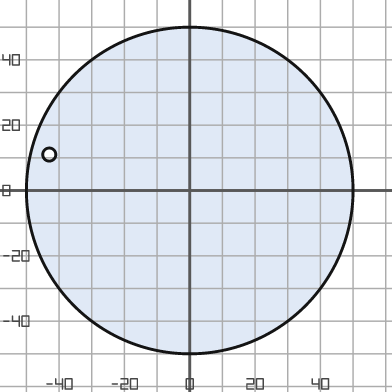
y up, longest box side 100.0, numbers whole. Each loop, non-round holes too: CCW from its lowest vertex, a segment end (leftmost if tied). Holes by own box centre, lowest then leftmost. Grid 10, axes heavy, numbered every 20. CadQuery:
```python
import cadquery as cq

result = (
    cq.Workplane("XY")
    .moveTo(0.0, 0.0)
    .circle(50.0)
    .moveTo(-43.0, 11.0)
    .circle(2.0)
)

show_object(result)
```